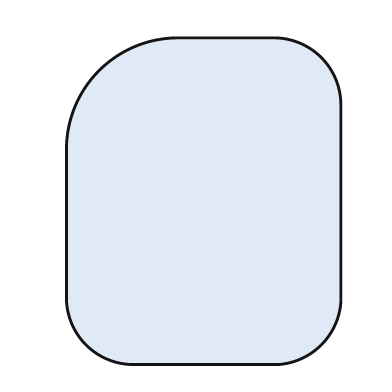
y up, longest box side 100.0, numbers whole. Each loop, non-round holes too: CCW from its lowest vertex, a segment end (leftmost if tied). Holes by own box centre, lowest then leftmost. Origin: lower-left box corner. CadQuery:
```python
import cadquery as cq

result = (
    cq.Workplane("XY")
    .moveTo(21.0, 0.0)
    .lineTo(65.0, 0.0)
    .threePointArc((78.0, 6.0), (84.0, 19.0))
    .lineTo(84.0, 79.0)
    .threePointArc((78.0, 94.0), (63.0, 100.0))
    .lineTo(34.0, 100.0)
    .threePointArc((10.0, 90.0), (0.0, 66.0))
    .lineTo(0.0, 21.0)
    .threePointArc((6.0, 6.0), (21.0, 0.0))
    .close()
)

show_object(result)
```